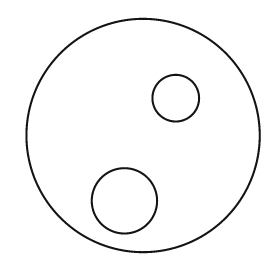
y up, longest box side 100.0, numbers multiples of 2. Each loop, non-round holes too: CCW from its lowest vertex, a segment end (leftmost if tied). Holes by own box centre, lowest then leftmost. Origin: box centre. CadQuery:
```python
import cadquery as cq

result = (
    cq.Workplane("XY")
    .moveTo(0.0, 0.0)
    .circle(50.0)
    .moveTo(-8.0, -28.0)
    .circle(14.0)
    .moveTo(14.0, 16.0)
    .circle(10.0)
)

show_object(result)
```